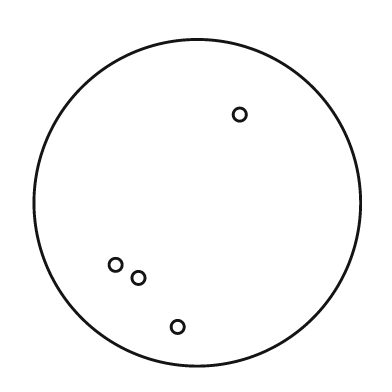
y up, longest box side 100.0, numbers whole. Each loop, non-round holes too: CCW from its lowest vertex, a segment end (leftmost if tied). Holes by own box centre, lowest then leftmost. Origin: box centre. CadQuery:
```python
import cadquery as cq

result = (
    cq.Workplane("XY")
    .moveTo(0.0, 0.0)
    .circle(50.0)
    .moveTo(-6.0, -38.0)
    .circle(2.0)
    .moveTo(-18.0, -23.0)
    .circle(2.0)
    .moveTo(-25.0, -19.0)
    .circle(2.0)
    .moveTo(13.0, 27.0)
    .circle(2.0)
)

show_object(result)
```